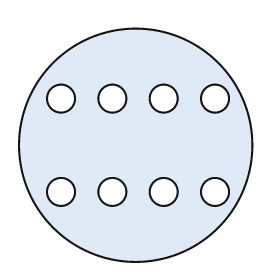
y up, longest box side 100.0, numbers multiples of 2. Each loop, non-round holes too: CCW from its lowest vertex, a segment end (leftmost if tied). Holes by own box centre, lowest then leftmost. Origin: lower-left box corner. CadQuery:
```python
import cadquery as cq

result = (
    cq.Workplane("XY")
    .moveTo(50.0, 50.0)
    .circle(50.0)
    .moveTo(18.0, 30.0)
    .circle(6.0)
    .moveTo(40.0, 30.0)
    .circle(6.0)
    .moveTo(62.0, 30.0)
    .circle(6.0)
    .moveTo(84.0, 30.0)
    .circle(6.0)
    .moveTo(18.0, 70.0)
    .circle(6.0)
    .moveTo(40.0, 70.0)
    .circle(6.0)
    .moveTo(62.0, 70.0)
    .circle(6.0)
    .moveTo(84.0, 70.0)
    .circle(6.0)
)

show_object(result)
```